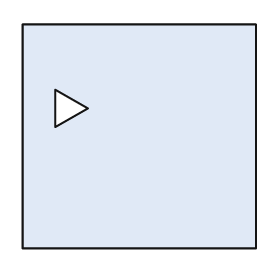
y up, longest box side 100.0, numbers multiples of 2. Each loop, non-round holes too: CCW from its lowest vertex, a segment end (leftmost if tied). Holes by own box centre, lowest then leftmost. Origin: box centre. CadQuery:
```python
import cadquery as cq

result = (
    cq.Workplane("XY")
    .moveTo(-50.0, -48.0)
    .lineTo(50.0, -48.0)
    .lineTo(50.0, 48.0)
    .lineTo(-50.0, 48.0)
    .close()
    .moveTo(-36.0, 4.0)
    .lineTo(-22.0, 12.0)
    .lineTo(-36.0, 20.0)
    .close()
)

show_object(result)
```